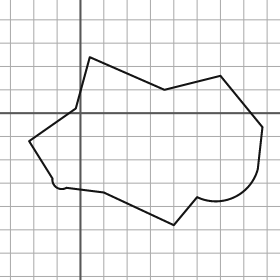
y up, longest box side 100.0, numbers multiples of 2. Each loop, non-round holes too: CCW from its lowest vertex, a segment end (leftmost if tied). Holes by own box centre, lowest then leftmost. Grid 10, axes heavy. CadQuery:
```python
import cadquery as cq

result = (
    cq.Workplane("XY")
    .moveTo(40.0, -48.0)
    .lineTo(50.0, -36.0)
    .threePointArc((66.0, -36.0), (76.0, -24.0))
    .lineTo(78.0, -6.0)
    .lineTo(60.0, 16.0)
    .lineTo(36.0, 10.0)
    .lineTo(4.0, 24.0)
    .lineTo(-2.0, 2.0)
    .lineTo(-22.0, -12.0)
    .lineTo(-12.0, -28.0)
    .threePointArc((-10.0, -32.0), (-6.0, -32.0))
    .lineTo(10.0, -34.0)
    .close()
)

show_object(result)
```